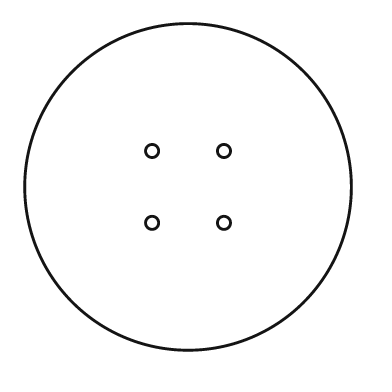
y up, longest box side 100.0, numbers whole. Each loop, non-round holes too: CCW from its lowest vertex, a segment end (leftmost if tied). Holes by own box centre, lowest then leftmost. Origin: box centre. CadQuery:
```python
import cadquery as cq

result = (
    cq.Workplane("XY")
    .moveTo(0.0, 0.0)
    .circle(50.0)
    .moveTo(-11.0, -11.0)
    .circle(2.0)
    .moveTo(11.0, -11.0)
    .circle(2.0)
    .moveTo(-11.0, 11.0)
    .circle(2.0)
    .moveTo(11.0, 11.0)
    .circle(2.0)
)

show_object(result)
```